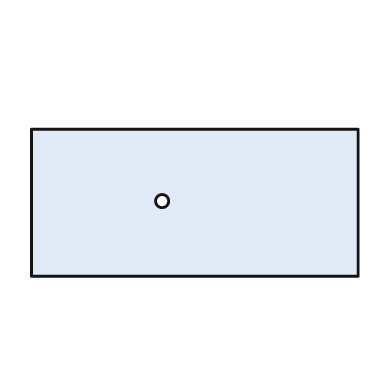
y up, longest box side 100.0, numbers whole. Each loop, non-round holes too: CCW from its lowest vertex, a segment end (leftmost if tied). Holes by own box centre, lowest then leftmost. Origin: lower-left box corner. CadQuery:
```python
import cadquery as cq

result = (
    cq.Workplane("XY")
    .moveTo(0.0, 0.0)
    .lineTo(100.0, 0.0)
    .lineTo(100.0, 45.0)
    .lineTo(0.0, 45.0)
    .close()
    .moveTo(40.0, 23.0)
    .circle(2.0)
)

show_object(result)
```